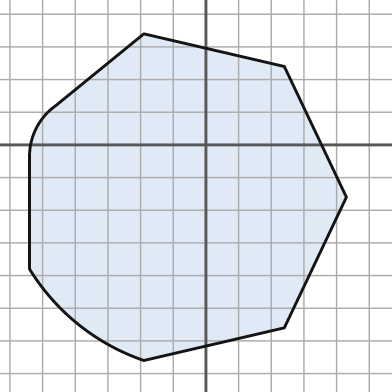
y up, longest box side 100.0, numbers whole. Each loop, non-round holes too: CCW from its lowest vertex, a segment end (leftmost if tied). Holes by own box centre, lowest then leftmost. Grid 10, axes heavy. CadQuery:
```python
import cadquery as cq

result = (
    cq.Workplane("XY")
    .moveTo(-19.0, -66.0)
    .lineTo(24.0, -56.0)
    .lineTo(43.0, -16.0)
    .lineTo(24.0, 24.0)
    .lineTo(-19.0, 34.0)
    .lineTo(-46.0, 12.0)
    .threePointArc((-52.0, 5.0), (-54.0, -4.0))
    .lineTo(-54.0, -38.0)
    .threePointArc((-39.0, -55.0), (-19.0, -66.0))
    .close()
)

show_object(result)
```